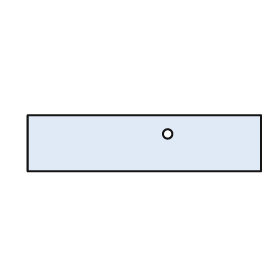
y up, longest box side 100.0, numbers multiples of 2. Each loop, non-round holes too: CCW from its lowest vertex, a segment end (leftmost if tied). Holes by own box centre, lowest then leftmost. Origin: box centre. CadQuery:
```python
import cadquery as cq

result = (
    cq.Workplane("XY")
    .moveTo(-50.0, -12.0)
    .lineTo(50.0, -12.0)
    .lineTo(50.0, 12.0)
    .lineTo(-50.0, 12.0)
    .close()
    .moveTo(10.0, 4.0)
    .circle(2.0)
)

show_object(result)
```